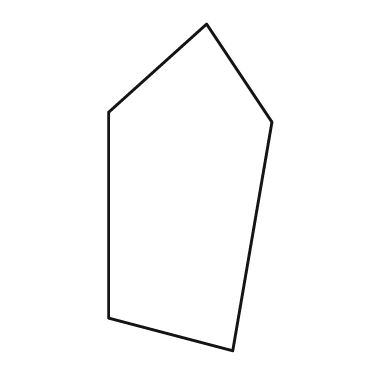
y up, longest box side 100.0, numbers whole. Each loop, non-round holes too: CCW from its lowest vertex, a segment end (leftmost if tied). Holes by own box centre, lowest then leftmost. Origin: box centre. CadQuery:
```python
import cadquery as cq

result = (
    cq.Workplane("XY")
    .moveTo(13.0, -50.0)
    .lineTo(25.0, 20.0)
    .lineTo(5.0, 50.0)
    .lineTo(-25.0, 23.0)
    .lineTo(-25.0, -40.0)
    .close()
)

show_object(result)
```